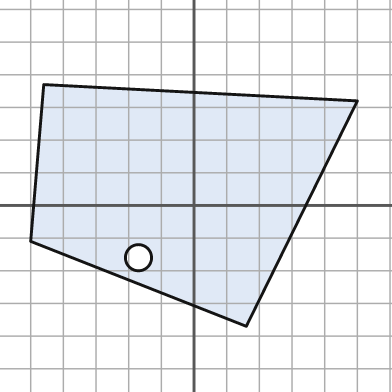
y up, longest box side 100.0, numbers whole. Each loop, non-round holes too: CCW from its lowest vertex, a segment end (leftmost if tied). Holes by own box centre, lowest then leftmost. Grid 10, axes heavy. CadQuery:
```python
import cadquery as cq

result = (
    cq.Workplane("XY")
    .moveTo(16.0, -37.0)
    .lineTo(50.0, 32.0)
    .lineTo(-46.0, 37.0)
    .lineTo(-50.0, -11.0)
    .close()
    .moveTo(-17.0, -16.0)
    .circle(4.0)
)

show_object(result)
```